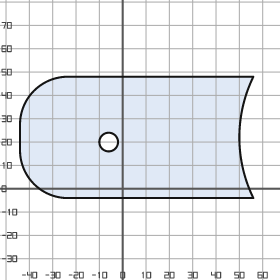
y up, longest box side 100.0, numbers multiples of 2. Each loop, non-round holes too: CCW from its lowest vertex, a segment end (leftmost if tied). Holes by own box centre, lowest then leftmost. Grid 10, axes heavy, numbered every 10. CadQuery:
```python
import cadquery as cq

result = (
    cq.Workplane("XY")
    .moveTo(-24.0, -4.0)
    .lineTo(56.0, -4.0)
    .threePointArc((50.0, 22.0), (56.0, 48.0))
    .lineTo(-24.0, 48.0)
    .threePointArc((-38.0, 42.0), (-44.0, 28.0))
    .lineTo(-44.0, 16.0)
    .threePointArc((-38.0, 2.0), (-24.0, -4.0))
    .close()
    .moveTo(-6.0, 20.0)
    .circle(4.0)
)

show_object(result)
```